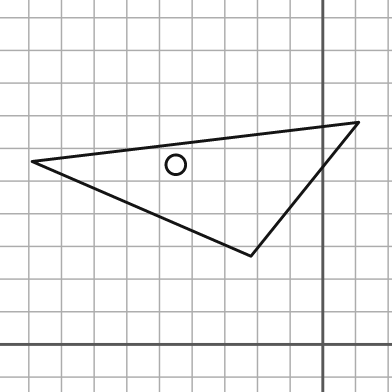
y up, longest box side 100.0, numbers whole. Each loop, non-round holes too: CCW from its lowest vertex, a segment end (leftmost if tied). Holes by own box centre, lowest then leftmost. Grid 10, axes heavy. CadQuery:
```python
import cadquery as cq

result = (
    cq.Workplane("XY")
    .moveTo(-22.0, 27.0)
    .lineTo(11.0, 68.0)
    .lineTo(-89.0, 56.0)
    .close()
    .moveTo(-45.0, 55.0)
    .circle(3.0)
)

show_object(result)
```